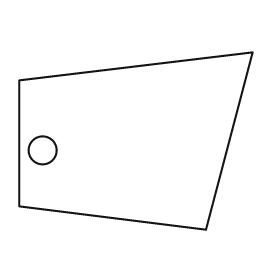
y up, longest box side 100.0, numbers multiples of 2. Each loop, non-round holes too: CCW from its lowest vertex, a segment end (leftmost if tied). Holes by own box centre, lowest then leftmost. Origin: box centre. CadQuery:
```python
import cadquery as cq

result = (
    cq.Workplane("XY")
    .moveTo(30.0, -38.0)
    .lineTo(50.0, 38.0)
    .lineTo(-50.0, 26.0)
    .lineTo(-50.0, -28.0)
    .close()
    .moveTo(-40.0, -4.0)
    .circle(6.0)
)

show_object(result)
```